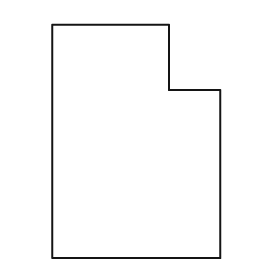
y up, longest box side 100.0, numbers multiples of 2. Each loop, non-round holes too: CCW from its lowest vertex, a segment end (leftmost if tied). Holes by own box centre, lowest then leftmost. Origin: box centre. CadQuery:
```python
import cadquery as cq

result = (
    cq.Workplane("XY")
    .moveTo(-36.0, -50.0)
    .lineTo(36.0, -50.0)
    .lineTo(36.0, 22.0)
    .lineTo(14.0, 22.0)
    .lineTo(14.0, 50.0)
    .lineTo(-36.0, 50.0)
    .close()
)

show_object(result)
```